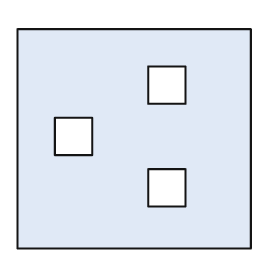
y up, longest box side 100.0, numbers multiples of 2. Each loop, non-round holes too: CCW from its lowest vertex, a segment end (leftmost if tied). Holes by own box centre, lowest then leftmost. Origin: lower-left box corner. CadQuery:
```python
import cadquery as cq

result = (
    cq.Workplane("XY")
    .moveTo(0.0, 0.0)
    .lineTo(100.0, 0.0)
    .lineTo(100.0, 94.0)
    .lineTo(0.0, 94.0)
    .close()
    .moveTo(56.0, 18.0)
    .lineTo(72.0, 18.0)
    .lineTo(72.0, 34.0)
    .lineTo(56.0, 34.0)
    .close()
    .moveTo(16.0, 40.0)
    .lineTo(32.0, 40.0)
    .lineTo(32.0, 56.0)
    .lineTo(16.0, 56.0)
    .close()
    .moveTo(56.0, 62.0)
    .lineTo(72.0, 62.0)
    .lineTo(72.0, 78.0)
    .lineTo(56.0, 78.0)
    .close()
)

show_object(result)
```